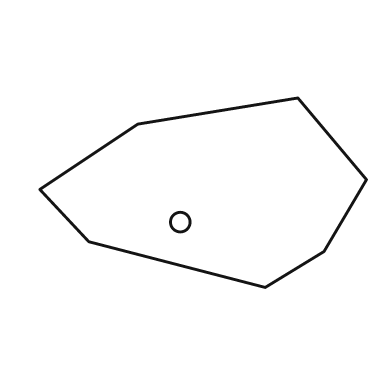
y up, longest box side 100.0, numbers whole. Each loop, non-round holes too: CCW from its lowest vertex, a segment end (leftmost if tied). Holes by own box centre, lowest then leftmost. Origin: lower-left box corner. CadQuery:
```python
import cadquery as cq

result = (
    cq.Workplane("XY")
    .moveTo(69.0, 0.0)
    .lineTo(87.0, 11.0)
    .lineTo(100.0, 33.0)
    .lineTo(79.0, 58.0)
    .lineTo(30.0, 50.0)
    .lineTo(0.0, 30.0)
    .lineTo(15.0, 14.0)
    .close()
    .moveTo(43.0, 20.0)
    .circle(3.0)
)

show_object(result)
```